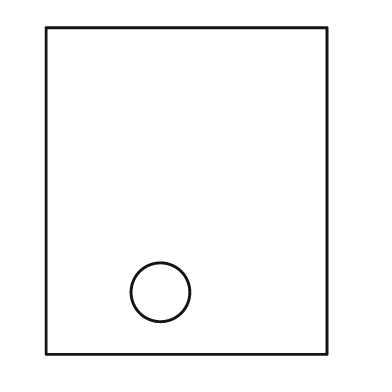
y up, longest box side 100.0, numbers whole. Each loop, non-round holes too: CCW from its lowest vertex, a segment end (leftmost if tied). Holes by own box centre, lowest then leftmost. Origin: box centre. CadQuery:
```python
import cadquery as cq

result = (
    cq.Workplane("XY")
    .moveTo(-43.0, -50.0)
    .lineTo(43.0, -50.0)
    .lineTo(43.0, 50.0)
    .lineTo(-43.0, 50.0)
    .close()
    .moveTo(-8.0, -31.0)
    .circle(9.0)
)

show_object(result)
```